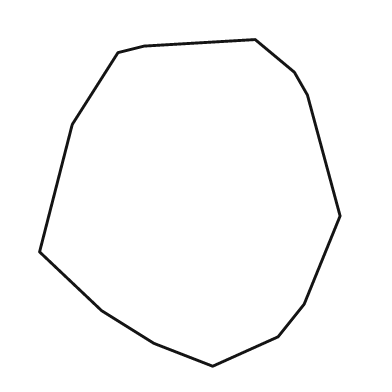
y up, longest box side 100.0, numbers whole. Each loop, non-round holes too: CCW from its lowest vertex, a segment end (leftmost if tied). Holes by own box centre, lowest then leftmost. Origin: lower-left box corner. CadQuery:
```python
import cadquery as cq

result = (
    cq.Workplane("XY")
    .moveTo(53.0, 0.0)
    .lineTo(73.0, 9.0)
    .lineTo(81.0, 19.0)
    .lineTo(92.0, 46.0)
    .lineTo(82.0, 83.0)
    .lineTo(78.0, 90.0)
    .lineTo(66.0, 100.0)
    .lineTo(32.0, 98.0)
    .lineTo(24.0, 96.0)
    .lineTo(10.0, 74.0)
    .lineTo(0.0, 35.0)
    .lineTo(19.0, 17.0)
    .lineTo(35.0, 7.0)
    .close()
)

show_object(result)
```